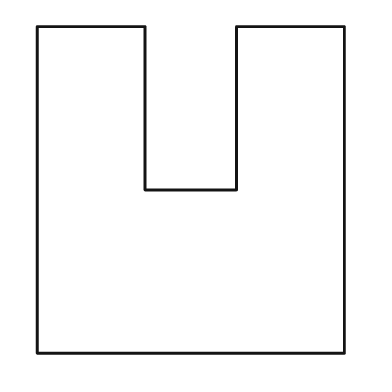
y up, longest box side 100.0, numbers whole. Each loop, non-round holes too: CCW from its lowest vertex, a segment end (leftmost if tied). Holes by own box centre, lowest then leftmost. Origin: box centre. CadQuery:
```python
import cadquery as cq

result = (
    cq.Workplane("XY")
    .moveTo(-47.0, -50.0)
    .lineTo(47.0, -50.0)
    .lineTo(47.0, 50.0)
    .lineTo(14.0, 50.0)
    .lineTo(14.0, 0.0)
    .lineTo(-14.0, 0.0)
    .lineTo(-14.0, 50.0)
    .lineTo(-47.0, 50.0)
    .close()
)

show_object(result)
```